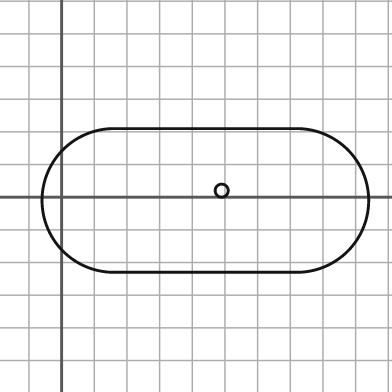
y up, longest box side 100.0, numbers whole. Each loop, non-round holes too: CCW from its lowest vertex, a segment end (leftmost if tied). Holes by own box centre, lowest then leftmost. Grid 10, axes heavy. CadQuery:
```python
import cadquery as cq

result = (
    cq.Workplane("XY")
    .moveTo(16.0, -23.0)
    .lineTo(72.0, -23.0)
    .threePointArc((94.0, -1.0), (72.0, 21.0))
    .lineTo(16.0, 21.0)
    .threePointArc((-6.0, -1.0), (16.0, -23.0))
    .close()
    .moveTo(49.0, 2.0)
    .circle(2.0)
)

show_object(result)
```